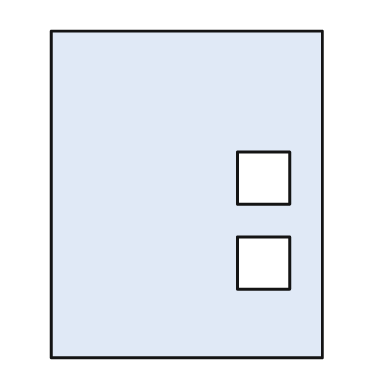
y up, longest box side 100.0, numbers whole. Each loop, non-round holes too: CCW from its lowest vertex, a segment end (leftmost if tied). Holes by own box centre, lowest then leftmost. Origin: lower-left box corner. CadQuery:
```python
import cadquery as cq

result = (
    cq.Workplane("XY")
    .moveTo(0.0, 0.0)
    .lineTo(83.0, 0.0)
    .lineTo(83.0, 100.0)
    .lineTo(0.0, 100.0)
    .close()
    .moveTo(57.0, 21.0)
    .lineTo(73.0, 21.0)
    .lineTo(73.0, 37.0)
    .lineTo(57.0, 37.0)
    .close()
    .moveTo(57.0, 47.0)
    .lineTo(73.0, 47.0)
    .lineTo(73.0, 63.0)
    .lineTo(57.0, 63.0)
    .close()
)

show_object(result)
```